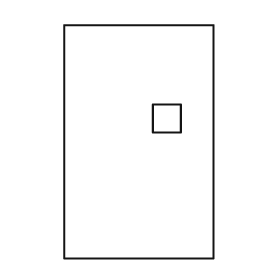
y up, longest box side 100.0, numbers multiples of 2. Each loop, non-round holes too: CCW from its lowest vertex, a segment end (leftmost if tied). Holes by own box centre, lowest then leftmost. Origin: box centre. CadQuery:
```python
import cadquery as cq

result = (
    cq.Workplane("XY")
    .moveTo(-32.0, -50.0)
    .lineTo(32.0, -50.0)
    .lineTo(32.0, 50.0)
    .lineTo(-32.0, 50.0)
    .close()
    .moveTo(6.0, 4.0)
    .lineTo(18.0, 4.0)
    .lineTo(18.0, 16.0)
    .lineTo(6.0, 16.0)
    .close()
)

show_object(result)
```